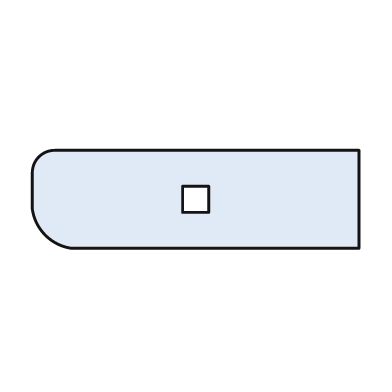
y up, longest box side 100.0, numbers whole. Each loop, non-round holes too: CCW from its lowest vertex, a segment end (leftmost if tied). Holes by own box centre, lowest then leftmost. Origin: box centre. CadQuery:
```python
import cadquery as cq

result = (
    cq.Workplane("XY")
    .moveTo(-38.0, -15.0)
    .lineTo(50.0, -15.0)
    .lineTo(50.0, 15.0)
    .lineTo(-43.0, 15.0)
    .threePointArc((-48.0, 13.0), (-50.0, 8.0))
    .lineTo(-50.0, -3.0)
    .threePointArc((-46.0, -11.0), (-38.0, -15.0))
    .close()
    .moveTo(-4.0, -4.0)
    .lineTo(4.0, -4.0)
    .lineTo(4.0, 4.0)
    .lineTo(-4.0, 4.0)
    .close()
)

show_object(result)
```